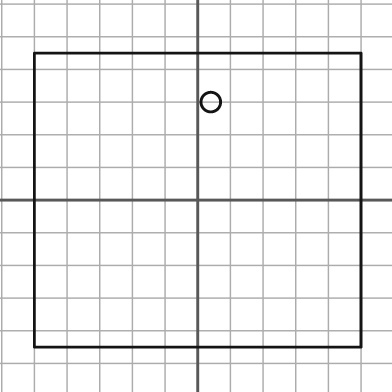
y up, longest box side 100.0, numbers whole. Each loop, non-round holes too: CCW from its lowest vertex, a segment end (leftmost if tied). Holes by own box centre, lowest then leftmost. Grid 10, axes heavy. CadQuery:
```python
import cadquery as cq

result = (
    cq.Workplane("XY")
    .moveTo(-50.0, -45.0)
    .lineTo(50.0, -45.0)
    .lineTo(50.0, 45.0)
    .lineTo(-50.0, 45.0)
    .close()
    .moveTo(4.0, 30.0)
    .circle(3.0)
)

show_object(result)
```